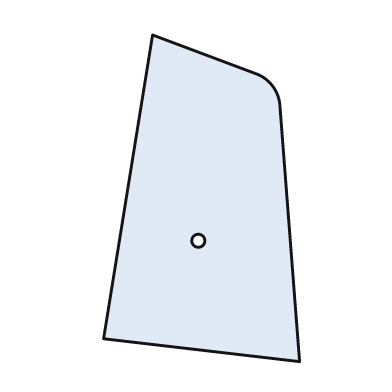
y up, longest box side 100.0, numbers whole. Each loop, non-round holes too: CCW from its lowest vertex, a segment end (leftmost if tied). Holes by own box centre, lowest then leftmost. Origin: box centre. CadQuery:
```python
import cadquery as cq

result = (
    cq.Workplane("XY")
    .moveTo(30.0, -50.0)
    .lineTo(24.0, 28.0)
    .threePointArc((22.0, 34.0), (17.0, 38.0))
    .lineTo(-15.0, 50.0)
    .lineTo(-30.0, -43.0)
    .close()
    .moveTo(-1.0, -13.0)
    .circle(2.0)
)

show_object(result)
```